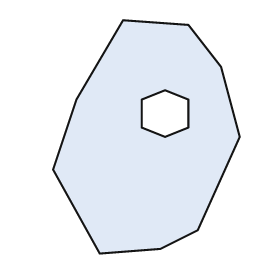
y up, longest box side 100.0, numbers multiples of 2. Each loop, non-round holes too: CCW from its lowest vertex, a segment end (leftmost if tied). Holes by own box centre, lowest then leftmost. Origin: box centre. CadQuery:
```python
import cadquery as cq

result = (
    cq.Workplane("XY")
    .moveTo(-20.0, -50.0)
    .lineTo(6.0, -48.0)
    .lineTo(22.0, -40.0)
    .lineTo(40.0, 0.0)
    .lineTo(32.0, 30.0)
    .lineTo(18.0, 48.0)
    .lineTo(-10.0, 50.0)
    .lineTo(-30.0, 16.0)
    .lineTo(-40.0, -14.0)
    .close()
    .moveTo(8.0, 0.0)
    .lineTo(18.0, 4.0)
    .lineTo(18.0, 16.0)
    .lineTo(8.0, 20.0)
    .lineTo(-2.0, 16.0)
    .lineTo(-2.0, 4.0)
    .close()
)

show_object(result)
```